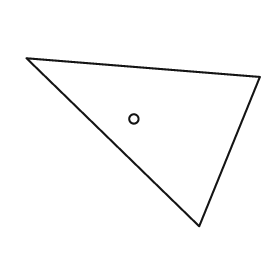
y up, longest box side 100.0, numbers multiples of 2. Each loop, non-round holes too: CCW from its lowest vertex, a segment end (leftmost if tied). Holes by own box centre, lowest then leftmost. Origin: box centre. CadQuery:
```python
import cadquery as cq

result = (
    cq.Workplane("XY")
    .moveTo(24.0, -36.0)
    .lineTo(50.0, 28.0)
    .lineTo(-50.0, 36.0)
    .close()
    .moveTo(-4.0, 10.0)
    .circle(2.0)
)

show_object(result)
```